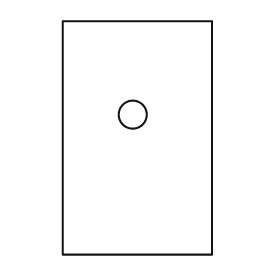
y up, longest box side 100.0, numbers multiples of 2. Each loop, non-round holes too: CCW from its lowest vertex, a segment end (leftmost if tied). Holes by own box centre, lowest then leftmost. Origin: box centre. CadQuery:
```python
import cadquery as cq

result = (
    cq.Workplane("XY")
    .moveTo(-32.0, -50.0)
    .lineTo(32.0, -50.0)
    .lineTo(32.0, 50.0)
    .lineTo(-32.0, 50.0)
    .close()
    .moveTo(-2.0, 10.0)
    .circle(6.0)
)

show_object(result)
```